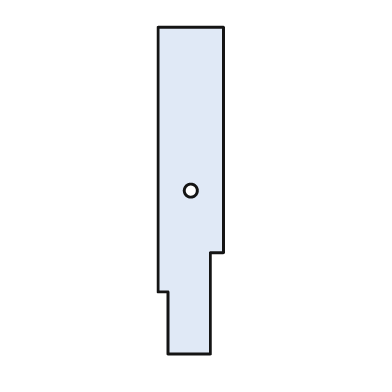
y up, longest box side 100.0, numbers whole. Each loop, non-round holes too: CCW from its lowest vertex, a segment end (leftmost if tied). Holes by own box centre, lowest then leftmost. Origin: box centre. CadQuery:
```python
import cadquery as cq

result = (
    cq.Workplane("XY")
    .moveTo(-7.0, -50.0)
    .lineTo(6.0, -50.0)
    .lineTo(6.0, -19.0)
    .lineTo(10.0, -19.0)
    .lineTo(10.0, 50.0)
    .lineTo(-10.0, 50.0)
    .lineTo(-10.0, -31.0)
    .lineTo(-7.0, -31.0)
    .close()
    .moveTo(0.0, 0.0)
    .circle(2.0)
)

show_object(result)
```